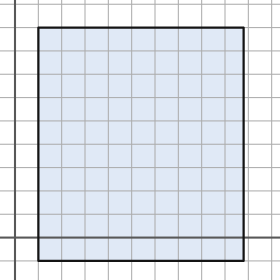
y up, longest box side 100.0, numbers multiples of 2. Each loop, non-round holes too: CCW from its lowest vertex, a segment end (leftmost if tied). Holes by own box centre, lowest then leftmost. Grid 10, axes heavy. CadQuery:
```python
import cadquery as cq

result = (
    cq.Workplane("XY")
    .moveTo(10.0, -10.0)
    .lineTo(98.0, -10.0)
    .lineTo(98.0, 90.0)
    .lineTo(10.0, 90.0)
    .close()
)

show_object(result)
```